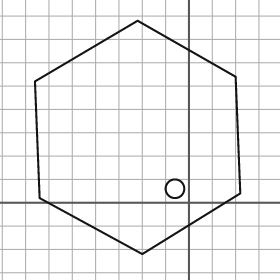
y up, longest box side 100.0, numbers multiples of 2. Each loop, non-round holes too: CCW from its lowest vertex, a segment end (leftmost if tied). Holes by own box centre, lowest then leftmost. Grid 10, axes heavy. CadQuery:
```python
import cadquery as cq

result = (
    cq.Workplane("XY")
    .moveTo(-20.0, -22.0)
    .lineTo(22.0, 4.0)
    .lineTo(20.0, 54.0)
    .lineTo(-22.0, 78.0)
    .lineTo(-66.0, 52.0)
    .lineTo(-64.0, 2.0)
    .close()
    .moveTo(-6.0, 6.0)
    .circle(4.0)
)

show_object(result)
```